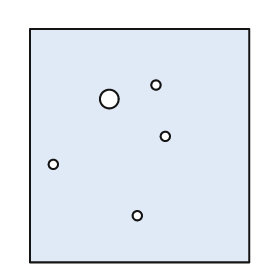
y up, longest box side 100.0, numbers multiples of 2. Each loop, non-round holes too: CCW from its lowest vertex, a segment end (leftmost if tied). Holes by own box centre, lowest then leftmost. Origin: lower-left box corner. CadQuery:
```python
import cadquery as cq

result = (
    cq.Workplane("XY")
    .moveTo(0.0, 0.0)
    .lineTo(94.0, 0.0)
    .lineTo(94.0, 100.0)
    .lineTo(0.0, 100.0)
    .close()
    .moveTo(46.0, 20.0)
    .circle(2.0)
    .moveTo(10.0, 42.0)
    .circle(2.0)
    .moveTo(58.0, 54.0)
    .circle(2.0)
    .moveTo(34.0, 70.0)
    .circle(4.0)
    .moveTo(54.0, 76.0)
    .circle(2.0)
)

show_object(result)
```